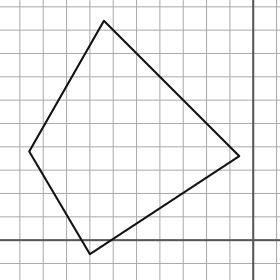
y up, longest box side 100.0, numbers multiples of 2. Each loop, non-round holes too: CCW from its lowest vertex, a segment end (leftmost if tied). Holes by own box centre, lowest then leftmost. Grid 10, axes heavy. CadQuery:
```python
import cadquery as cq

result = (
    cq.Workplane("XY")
    .moveTo(-70.0, -6.0)
    .lineTo(-6.0, 36.0)
    .lineTo(-64.0, 94.0)
    .lineTo(-96.0, 38.0)
    .close()
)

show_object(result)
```